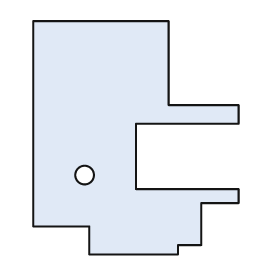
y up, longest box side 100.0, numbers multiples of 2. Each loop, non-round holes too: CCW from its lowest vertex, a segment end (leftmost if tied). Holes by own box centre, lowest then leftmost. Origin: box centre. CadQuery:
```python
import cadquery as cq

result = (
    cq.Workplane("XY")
    .moveTo(-20.0, -50.0)
    .lineTo(18.0, -50.0)
    .lineTo(18.0, -46.0)
    .lineTo(28.0, -46.0)
    .lineTo(28.0, -28.0)
    .lineTo(44.0, -28.0)
    .lineTo(44.0, -22.0)
    .lineTo(0.0, -22.0)
    .lineTo(0.0, 6.0)
    .lineTo(44.0, 6.0)
    .lineTo(44.0, 14.0)
    .lineTo(14.0, 14.0)
    .lineTo(14.0, 50.0)
    .lineTo(-44.0, 50.0)
    .lineTo(-44.0, -38.0)
    .lineTo(-20.0, -38.0)
    .close()
    .moveTo(-22.0, -16.0)
    .circle(4.0)
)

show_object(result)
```